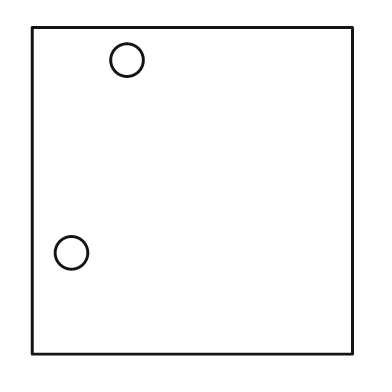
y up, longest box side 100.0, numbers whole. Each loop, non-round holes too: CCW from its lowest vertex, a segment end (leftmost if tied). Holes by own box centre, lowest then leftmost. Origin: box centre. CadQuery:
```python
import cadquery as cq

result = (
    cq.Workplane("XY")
    .moveTo(-49.0, -50.0)
    .lineTo(49.0, -50.0)
    .lineTo(49.0, 50.0)
    .lineTo(-49.0, 50.0)
    .close()
    .moveTo(-37.0, -19.0)
    .circle(5.0)
    .moveTo(-20.0, 40.0)
    .circle(5.0)
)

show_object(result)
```